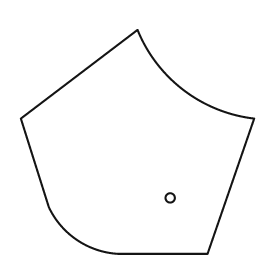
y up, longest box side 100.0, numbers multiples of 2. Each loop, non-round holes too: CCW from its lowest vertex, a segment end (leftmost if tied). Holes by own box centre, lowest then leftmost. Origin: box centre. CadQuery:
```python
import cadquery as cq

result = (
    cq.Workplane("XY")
    .moveTo(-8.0, -48.0)
    .lineTo(30.0, -48.0)
    .lineTo(50.0, 10.0)
    .threePointArc((20.0, 22.0), (0.0, 48.0))
    .lineTo(-50.0, 10.0)
    .lineTo(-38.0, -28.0)
    .threePointArc((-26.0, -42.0), (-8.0, -48.0))
    .close()
    .moveTo(14.0, -24.0)
    .circle(2.0)
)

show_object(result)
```